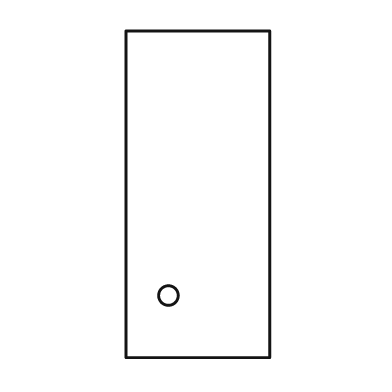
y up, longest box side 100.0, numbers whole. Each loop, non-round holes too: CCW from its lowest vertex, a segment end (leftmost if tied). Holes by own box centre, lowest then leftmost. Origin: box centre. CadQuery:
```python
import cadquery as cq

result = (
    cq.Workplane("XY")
    .moveTo(-22.0, -50.0)
    .lineTo(22.0, -50.0)
    .lineTo(22.0, 50.0)
    .lineTo(-22.0, 50.0)
    .close()
    .moveTo(-9.0, -31.0)
    .circle(3.0)
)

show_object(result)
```